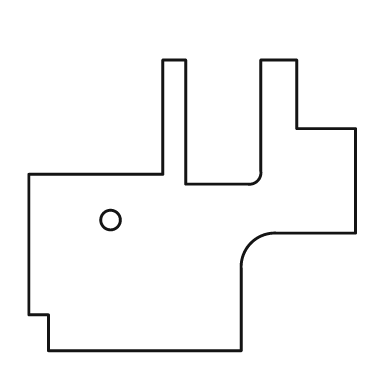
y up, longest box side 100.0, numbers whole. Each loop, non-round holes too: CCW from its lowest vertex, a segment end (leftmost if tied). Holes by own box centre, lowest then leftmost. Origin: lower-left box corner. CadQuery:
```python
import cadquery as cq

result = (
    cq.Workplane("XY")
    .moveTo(6.0, 0.0)
    .lineTo(65.0, 0.0)
    .lineTo(65.0, 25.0)
    .threePointArc((68.0, 33.0), (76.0, 36.0))
    .lineTo(100.0, 36.0)
    .lineTo(100.0, 68.0)
    .lineTo(82.0, 68.0)
    .lineTo(82.0, 89.0)
    .lineTo(71.0, 89.0)
    .lineTo(71.0, 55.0)
    .threePointArc((70.0, 52.0), (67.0, 51.0))
    .lineTo(48.0, 51.0)
    .lineTo(48.0, 89.0)
    .lineTo(41.0, 89.0)
    .lineTo(41.0, 54.0)
    .lineTo(0.0, 54.0)
    .lineTo(0.0, 11.0)
    .lineTo(6.0, 11.0)
    .close()
    .moveTo(25.0, 40.0)
    .circle(3.0)
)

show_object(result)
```